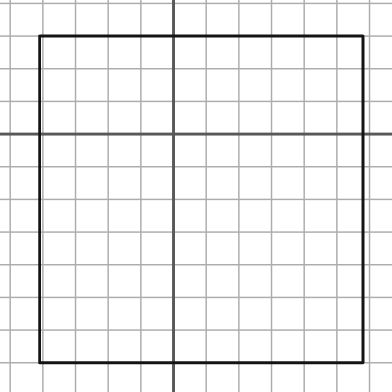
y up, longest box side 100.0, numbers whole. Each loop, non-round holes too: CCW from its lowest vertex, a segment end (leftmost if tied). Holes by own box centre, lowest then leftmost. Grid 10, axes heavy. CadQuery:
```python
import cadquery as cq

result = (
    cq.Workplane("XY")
    .moveTo(-41.0, -70.0)
    .lineTo(58.0, -70.0)
    .lineTo(58.0, 30.0)
    .lineTo(-41.0, 30.0)
    .close()
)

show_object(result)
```